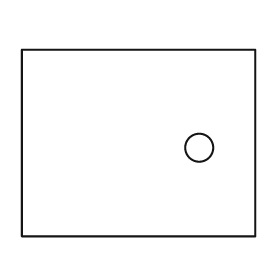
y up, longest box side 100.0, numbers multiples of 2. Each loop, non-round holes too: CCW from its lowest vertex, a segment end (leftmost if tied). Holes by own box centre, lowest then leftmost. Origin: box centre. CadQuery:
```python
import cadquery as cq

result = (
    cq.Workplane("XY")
    .moveTo(-50.0, -40.0)
    .lineTo(50.0, -40.0)
    .lineTo(50.0, 40.0)
    .lineTo(-50.0, 40.0)
    .close()
    .moveTo(26.0, -2.0)
    .circle(6.0)
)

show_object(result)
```